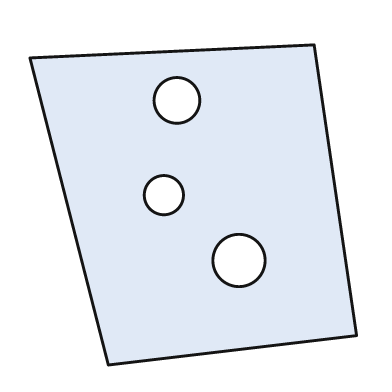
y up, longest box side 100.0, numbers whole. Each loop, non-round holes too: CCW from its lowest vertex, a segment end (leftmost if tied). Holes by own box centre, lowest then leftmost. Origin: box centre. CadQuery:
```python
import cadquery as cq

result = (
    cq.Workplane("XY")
    .moveTo(-26.0, -49.0)
    .lineTo(50.0, -40.0)
    .lineTo(37.0, 49.0)
    .lineTo(-50.0, 45.0)
    .close()
    .moveTo(14.0, -17.0)
    .circle(8.0)
    .moveTo(-9.0, 3.0)
    .circle(6.0)
    .moveTo(-5.0, 32.0)
    .circle(7.0)
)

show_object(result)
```